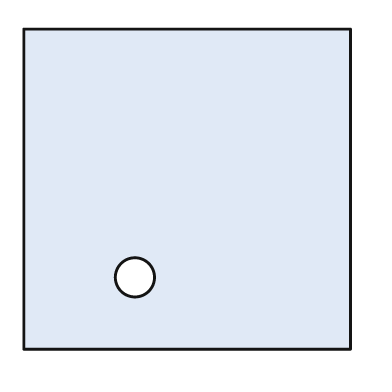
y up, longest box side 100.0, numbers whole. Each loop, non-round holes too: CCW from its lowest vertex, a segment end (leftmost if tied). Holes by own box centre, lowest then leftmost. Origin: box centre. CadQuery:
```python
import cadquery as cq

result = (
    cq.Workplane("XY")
    .moveTo(-50.0, -49.0)
    .lineTo(50.0, -49.0)
    .lineTo(50.0, 49.0)
    .lineTo(-50.0, 49.0)
    .close()
    .moveTo(-16.0, -27.0)
    .circle(6.0)
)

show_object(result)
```